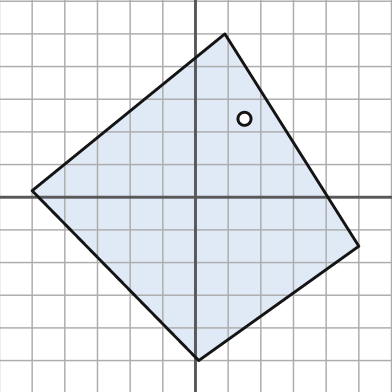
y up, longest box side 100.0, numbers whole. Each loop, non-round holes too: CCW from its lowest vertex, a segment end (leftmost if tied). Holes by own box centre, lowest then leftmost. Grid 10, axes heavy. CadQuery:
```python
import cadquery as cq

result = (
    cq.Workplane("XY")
    .moveTo(1.0, -50.0)
    .lineTo(50.0, -15.0)
    .lineTo(9.0, 50.0)
    .lineTo(-50.0, 2.0)
    .close()
    .moveTo(15.0, 24.0)
    .circle(2.0)
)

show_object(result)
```